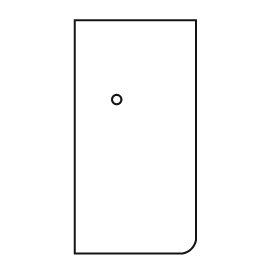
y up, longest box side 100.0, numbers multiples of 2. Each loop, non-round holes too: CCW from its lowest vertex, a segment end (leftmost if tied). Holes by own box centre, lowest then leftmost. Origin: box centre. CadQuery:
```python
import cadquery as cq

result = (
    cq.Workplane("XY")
    .moveTo(-26.0, -50.0)
    .lineTo(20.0, -50.0)
    .threePointArc((24.0, -48.0), (26.0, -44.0))
    .lineTo(26.0, 50.0)
    .lineTo(-26.0, 50.0)
    .close()
    .moveTo(-8.0, 16.0)
    .circle(2.0)
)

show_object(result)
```